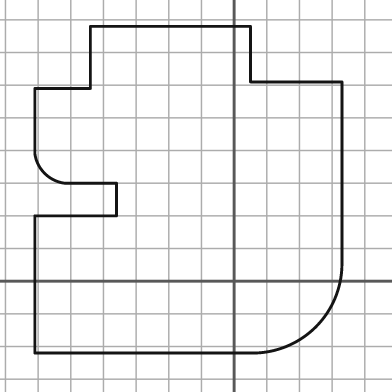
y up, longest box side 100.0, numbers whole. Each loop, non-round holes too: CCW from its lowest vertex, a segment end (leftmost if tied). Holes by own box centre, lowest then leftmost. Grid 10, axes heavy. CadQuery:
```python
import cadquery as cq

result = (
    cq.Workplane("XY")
    .moveTo(-61.0, -22.0)
    .lineTo(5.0, -22.0)
    .threePointArc((25.0, -14.0), (33.0, 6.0))
    .lineTo(33.0, 61.0)
    .lineTo(5.0, 61.0)
    .lineTo(5.0, 78.0)
    .lineTo(-44.0, 78.0)
    .lineTo(-44.0, 59.0)
    .lineTo(-61.0, 59.0)
    .lineTo(-61.0, 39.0)
    .threePointArc((-58.0, 33.0), (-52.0, 30.0))
    .lineTo(-36.0, 30.0)
    .lineTo(-36.0, 20.0)
    .lineTo(-61.0, 20.0)
    .close()
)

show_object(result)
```